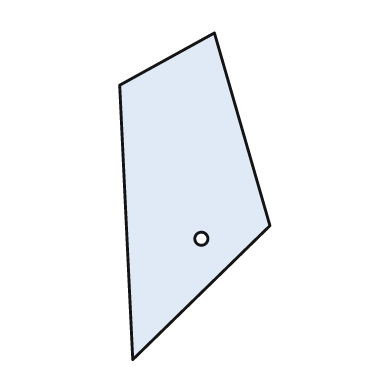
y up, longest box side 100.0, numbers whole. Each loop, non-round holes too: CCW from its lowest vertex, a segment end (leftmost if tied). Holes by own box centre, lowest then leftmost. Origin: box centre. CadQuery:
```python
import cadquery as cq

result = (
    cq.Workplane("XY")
    .moveTo(-19.0, -50.0)
    .lineTo(23.0, -9.0)
    .lineTo(6.0, 50.0)
    .lineTo(-23.0, 34.0)
    .close()
    .moveTo(2.0, -13.0)
    .circle(2.0)
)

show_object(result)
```